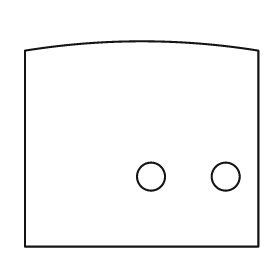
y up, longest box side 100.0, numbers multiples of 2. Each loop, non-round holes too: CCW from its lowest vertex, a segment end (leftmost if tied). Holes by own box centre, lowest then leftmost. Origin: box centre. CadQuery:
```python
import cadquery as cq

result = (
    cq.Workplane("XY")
    .moveTo(-50.0, -44.0)
    .lineTo(50.0, -44.0)
    .lineTo(50.0, 40.0)
    .threePointArc((0.0, 44.0), (-50.0, 40.0))
    .close()
    .moveTo(4.0, -14.0)
    .circle(6.0)
    .moveTo(36.0, -14.0)
    .circle(6.0)
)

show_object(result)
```